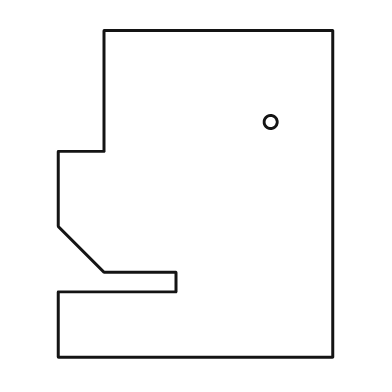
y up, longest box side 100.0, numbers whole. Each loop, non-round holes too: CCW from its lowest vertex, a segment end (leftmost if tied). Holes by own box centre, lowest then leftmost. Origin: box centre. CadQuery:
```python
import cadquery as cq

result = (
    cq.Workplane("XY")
    .moveTo(-42.0, -50.0)
    .lineTo(42.0, -50.0)
    .lineTo(42.0, 50.0)
    .lineTo(-28.0, 50.0)
    .lineTo(-28.0, 13.0)
    .lineTo(-42.0, 13.0)
    .lineTo(-42.0, -10.0)
    .lineTo(-28.0, -24.0)
    .lineTo(-6.0, -24.0)
    .lineTo(-6.0, -30.0)
    .lineTo(-42.0, -30.0)
    .close()
    .moveTo(23.0, 22.0)
    .circle(2.0)
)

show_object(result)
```